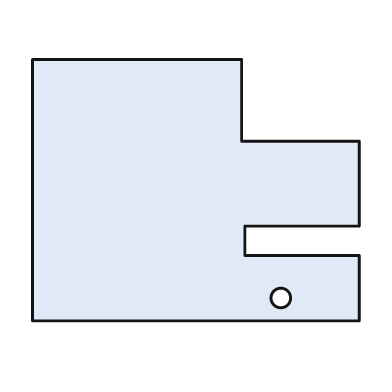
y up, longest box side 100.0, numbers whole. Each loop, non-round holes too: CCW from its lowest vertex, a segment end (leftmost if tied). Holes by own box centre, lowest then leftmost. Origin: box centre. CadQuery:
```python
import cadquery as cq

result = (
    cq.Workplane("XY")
    .moveTo(-50.0, -40.0)
    .lineTo(50.0, -40.0)
    .lineTo(50.0, -20.0)
    .lineTo(15.0, -20.0)
    .lineTo(15.0, -11.0)
    .lineTo(50.0, -11.0)
    .lineTo(50.0, 15.0)
    .lineTo(14.0, 15.0)
    .lineTo(14.0, 40.0)
    .lineTo(-50.0, 40.0)
    .close()
    .moveTo(26.0, -33.0)
    .circle(3.0)
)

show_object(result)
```